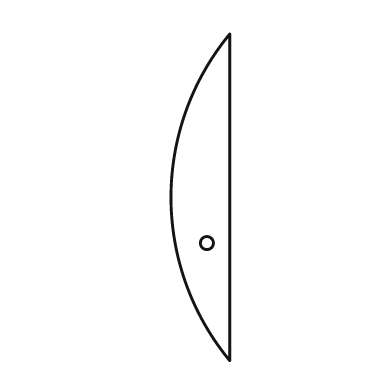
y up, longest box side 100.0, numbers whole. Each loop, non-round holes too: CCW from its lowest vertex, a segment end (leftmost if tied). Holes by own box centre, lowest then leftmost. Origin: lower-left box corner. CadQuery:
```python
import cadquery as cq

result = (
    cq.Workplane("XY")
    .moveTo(18.0, 0.0)
    .lineTo(18.0, 100.0)
    .threePointArc((0.0, 50.0), (18.0, 0.0))
    .close()
    .moveTo(11.0, 36.0)
    .circle(2.0)
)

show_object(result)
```